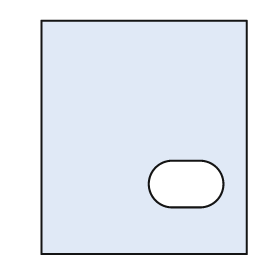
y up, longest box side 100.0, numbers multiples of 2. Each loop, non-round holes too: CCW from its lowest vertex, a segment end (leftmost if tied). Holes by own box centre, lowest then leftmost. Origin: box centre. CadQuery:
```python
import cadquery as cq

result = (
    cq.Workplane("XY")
    .moveTo(-44.0, -50.0)
    .lineTo(44.0, -50.0)
    .lineTo(44.0, 50.0)
    .lineTo(-44.0, 50.0)
    .close()
    .moveTo(12.0, -30.0)
    .lineTo(24.0, -30.0)
    .threePointArc((34.0, -20.0), (24.0, -10.0))
    .lineTo(12.0, -10.0)
    .threePointArc((2.0, -20.0), (12.0, -30.0))
    .close()
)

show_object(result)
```